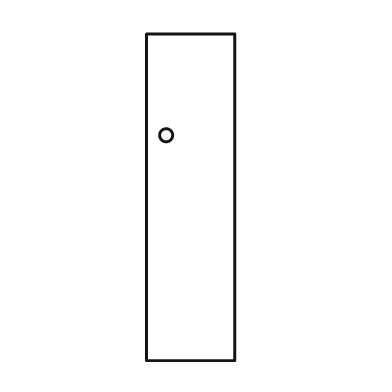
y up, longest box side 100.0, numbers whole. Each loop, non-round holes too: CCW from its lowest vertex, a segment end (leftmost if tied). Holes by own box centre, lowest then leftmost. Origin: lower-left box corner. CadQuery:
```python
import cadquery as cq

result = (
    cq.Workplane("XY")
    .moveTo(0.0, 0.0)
    .lineTo(27.0, 0.0)
    .lineTo(27.0, 100.0)
    .lineTo(0.0, 100.0)
    .close()
    .moveTo(6.0, 69.0)
    .circle(2.0)
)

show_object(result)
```